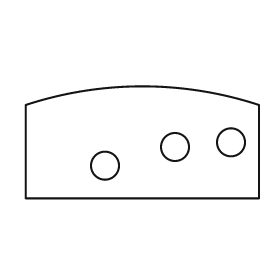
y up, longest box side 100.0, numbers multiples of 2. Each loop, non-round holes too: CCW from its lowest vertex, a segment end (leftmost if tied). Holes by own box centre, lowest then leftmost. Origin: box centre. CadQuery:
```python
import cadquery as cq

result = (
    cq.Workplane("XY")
    .moveTo(-50.0, -24.0)
    .lineTo(50.0, -24.0)
    .lineTo(50.0, 16.0)
    .threePointArc((0.0, 24.0), (-50.0, 16.0))
    .close()
    .moveTo(-16.0, -10.0)
    .circle(6.0)
    .moveTo(14.0, -2.0)
    .circle(6.0)
    .moveTo(38.0, 0.0)
    .circle(6.0)
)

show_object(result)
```